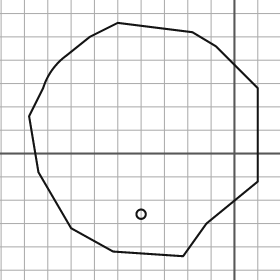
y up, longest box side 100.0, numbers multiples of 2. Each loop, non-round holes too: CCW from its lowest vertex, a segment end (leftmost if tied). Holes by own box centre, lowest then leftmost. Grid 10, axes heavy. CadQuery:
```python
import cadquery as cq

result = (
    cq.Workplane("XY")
    .moveTo(-22.0, -44.0)
    .lineTo(-12.0, -30.0)
    .lineTo(10.0, -12.0)
    .lineTo(10.0, 28.0)
    .lineTo(-8.0, 46.0)
    .lineTo(-18.0, 52.0)
    .lineTo(-50.0, 56.0)
    .lineTo(-62.0, 50.0)
    .lineTo(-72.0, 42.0)
    .threePointArc((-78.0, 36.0), (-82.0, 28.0))
    .lineTo(-88.0, 16.0)
    .lineTo(-84.0, -8.0)
    .lineTo(-70.0, -32.0)
    .lineTo(-52.0, -42.0)
    .close()
    .moveTo(-40.0, -26.0)
    .circle(2.0)
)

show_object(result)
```